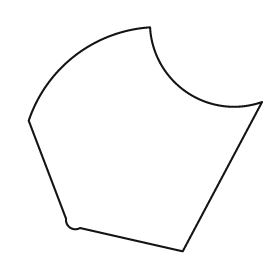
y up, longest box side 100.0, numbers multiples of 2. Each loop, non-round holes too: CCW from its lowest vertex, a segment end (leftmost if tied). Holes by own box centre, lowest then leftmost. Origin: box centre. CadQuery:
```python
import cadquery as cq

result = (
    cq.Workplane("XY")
    .moveTo(16.0, -48.0)
    .lineTo(50.0, 16.0)
    .threePointArc((18.0, 20.0), (2.0, 48.0))
    .threePointArc((-30.0, 36.0), (-50.0, 8.0))
    .lineTo(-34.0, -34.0)
    .threePointArc((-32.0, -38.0), (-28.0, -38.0))
    .close()
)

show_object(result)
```